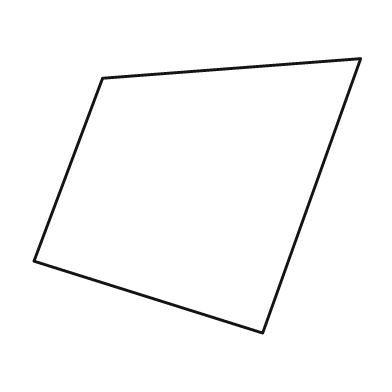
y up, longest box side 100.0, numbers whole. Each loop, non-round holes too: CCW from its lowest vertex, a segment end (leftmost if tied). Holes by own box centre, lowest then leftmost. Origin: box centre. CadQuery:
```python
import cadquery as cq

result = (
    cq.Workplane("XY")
    .moveTo(20.0, -42.0)
    .lineTo(50.0, 42.0)
    .lineTo(-29.0, 36.0)
    .lineTo(-50.0, -20.0)
    .close()
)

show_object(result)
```